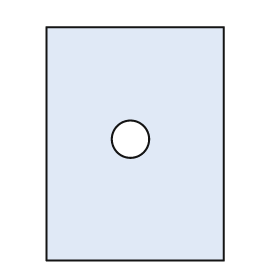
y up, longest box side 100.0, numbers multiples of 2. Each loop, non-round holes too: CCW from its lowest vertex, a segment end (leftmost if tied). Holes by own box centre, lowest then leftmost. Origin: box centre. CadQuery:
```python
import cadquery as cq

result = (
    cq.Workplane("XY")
    .moveTo(-38.0, -50.0)
    .lineTo(38.0, -50.0)
    .lineTo(38.0, 50.0)
    .lineTo(-38.0, 50.0)
    .close()
    .moveTo(-2.0, 2.0)
    .circle(8.0)
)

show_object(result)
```